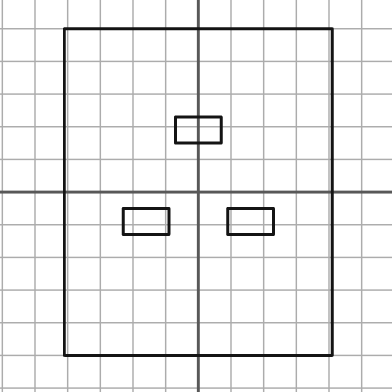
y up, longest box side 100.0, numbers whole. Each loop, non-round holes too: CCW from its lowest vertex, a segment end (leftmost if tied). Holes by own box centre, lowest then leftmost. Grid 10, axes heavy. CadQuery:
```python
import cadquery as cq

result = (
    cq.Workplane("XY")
    .moveTo(-41.0, -50.0)
    .lineTo(41.0, -50.0)
    .lineTo(41.0, 50.0)
    .lineTo(-41.0, 50.0)
    .close()
    .moveTo(-23.0, -13.0)
    .lineTo(-9.0, -13.0)
    .lineTo(-9.0, -5.0)
    .lineTo(-23.0, -5.0)
    .close()
    .moveTo(9.0, -13.0)
    .lineTo(23.0, -13.0)
    .lineTo(23.0, -5.0)
    .lineTo(9.0, -5.0)
    .close()
    .moveTo(-7.0, 15.0)
    .lineTo(7.0, 15.0)
    .lineTo(7.0, 23.0)
    .lineTo(-7.0, 23.0)
    .close()
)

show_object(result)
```